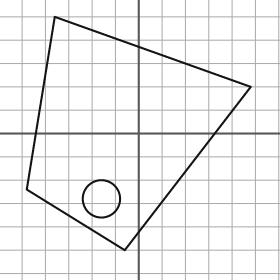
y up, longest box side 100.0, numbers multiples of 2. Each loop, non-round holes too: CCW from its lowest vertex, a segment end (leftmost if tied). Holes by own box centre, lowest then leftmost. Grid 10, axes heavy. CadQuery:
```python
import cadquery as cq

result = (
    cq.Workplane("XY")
    .moveTo(-6.0, -50.0)
    .lineTo(48.0, 20.0)
    .lineTo(-36.0, 50.0)
    .lineTo(-48.0, -24.0)
    .close()
    .moveTo(-16.0, -28.0)
    .circle(8.0)
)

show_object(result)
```